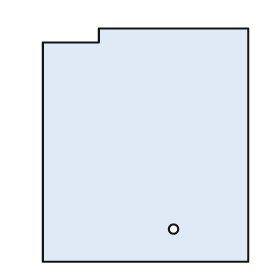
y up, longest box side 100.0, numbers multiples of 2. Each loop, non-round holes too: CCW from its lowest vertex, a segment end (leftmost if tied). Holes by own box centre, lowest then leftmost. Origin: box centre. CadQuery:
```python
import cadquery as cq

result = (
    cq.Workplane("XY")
    .moveTo(-44.0, -50.0)
    .lineTo(44.0, -50.0)
    .lineTo(44.0, 50.0)
    .lineTo(-20.0, 50.0)
    .lineTo(-20.0, 44.0)
    .lineTo(-44.0, 44.0)
    .close()
    .moveTo(12.0, -36.0)
    .circle(2.0)
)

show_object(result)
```